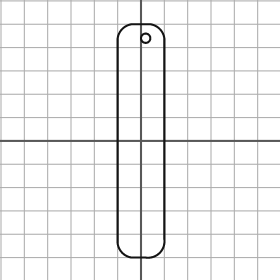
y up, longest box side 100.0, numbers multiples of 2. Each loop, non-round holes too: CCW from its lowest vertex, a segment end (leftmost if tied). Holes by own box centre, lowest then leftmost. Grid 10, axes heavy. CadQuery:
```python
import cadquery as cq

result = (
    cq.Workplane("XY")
    .moveTo(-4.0, -50.0)
    .lineTo(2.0, -50.0)
    .threePointArc((8.0, -48.0), (10.0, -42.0))
    .lineTo(10.0, 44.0)
    .threePointArc((8.0, 48.0), (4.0, 50.0))
    .lineTo(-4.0, 50.0)
    .threePointArc((-8.0, 48.0), (-10.0, 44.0))
    .lineTo(-10.0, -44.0)
    .threePointArc((-8.0, -48.0), (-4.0, -50.0))
    .close()
    .moveTo(2.0, 44.0)
    .circle(2.0)
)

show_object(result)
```